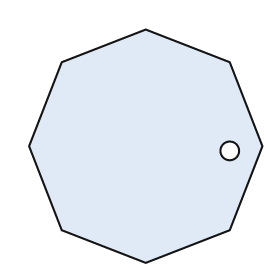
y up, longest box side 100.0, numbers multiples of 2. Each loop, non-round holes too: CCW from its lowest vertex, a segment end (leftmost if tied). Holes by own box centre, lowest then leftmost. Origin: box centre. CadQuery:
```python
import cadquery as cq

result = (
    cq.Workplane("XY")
    .moveTo(0.0, -50.0)
    .lineTo(36.0, -36.0)
    .lineTo(50.0, 0.0)
    .lineTo(36.0, 36.0)
    .lineTo(0.0, 50.0)
    .lineTo(-36.0, 36.0)
    .lineTo(-50.0, 0.0)
    .lineTo(-36.0, -36.0)
    .close()
    .moveTo(36.0, -2.0)
    .circle(4.0)
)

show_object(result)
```